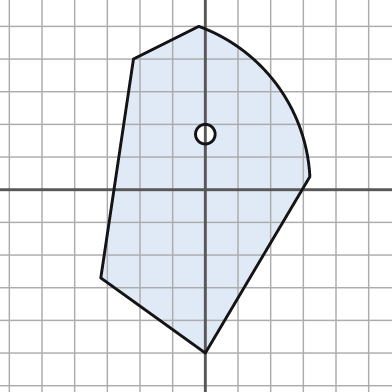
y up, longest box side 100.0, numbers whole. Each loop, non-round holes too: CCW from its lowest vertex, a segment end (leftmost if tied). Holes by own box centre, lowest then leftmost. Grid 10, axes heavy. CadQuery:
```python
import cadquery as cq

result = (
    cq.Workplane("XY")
    .moveTo(0.0, -50.0)
    .lineTo(32.0, 4.0)
    .threePointArc((22.0, 32.0), (-2.0, 50.0))
    .lineTo(-22.0, 40.0)
    .lineTo(-32.0, -27.0)
    .close()
    .moveTo(0.0, 17.0)
    .circle(3.0)
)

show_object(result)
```